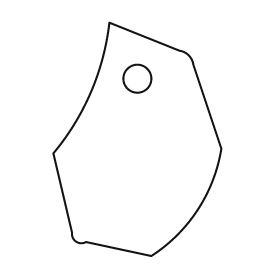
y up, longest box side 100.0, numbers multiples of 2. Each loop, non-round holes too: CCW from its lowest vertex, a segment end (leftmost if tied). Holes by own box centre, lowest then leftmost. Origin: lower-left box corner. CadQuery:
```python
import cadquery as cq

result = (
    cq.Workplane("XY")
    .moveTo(42.0, 0.0)
    .threePointArc((62.0, 20.0), (72.0, 46.0))
    .lineTo(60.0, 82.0)
    .threePointArc((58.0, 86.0), (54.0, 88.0))
    .lineTo(24.0, 100.0)
    .threePointArc((16.0, 70.0), (0.0, 44.0))
    .lineTo(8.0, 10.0)
    .threePointArc((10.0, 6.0), (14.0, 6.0))
    .close()
    .moveTo(36.0, 76.0)
    .circle(6.0)
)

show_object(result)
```